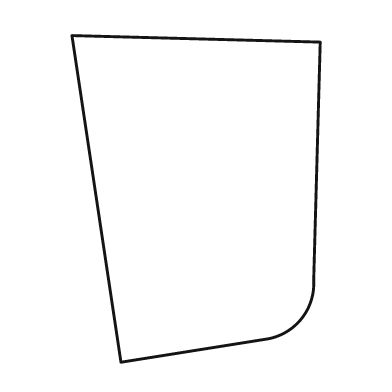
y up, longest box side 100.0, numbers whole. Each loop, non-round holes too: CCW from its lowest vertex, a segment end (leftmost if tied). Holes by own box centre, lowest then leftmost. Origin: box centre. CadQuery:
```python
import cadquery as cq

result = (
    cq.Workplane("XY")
    .moveTo(-23.0, -50.0)
    .lineTo(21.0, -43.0)
    .threePointArc((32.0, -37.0), (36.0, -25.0))
    .lineTo(38.0, 48.0)
    .lineTo(-38.0, 50.0)
    .close()
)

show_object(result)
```